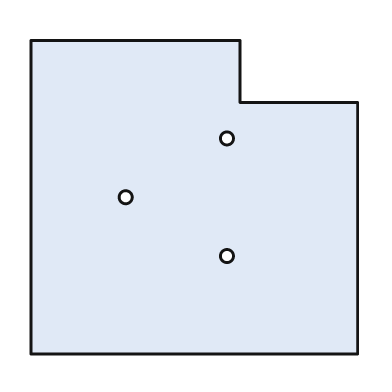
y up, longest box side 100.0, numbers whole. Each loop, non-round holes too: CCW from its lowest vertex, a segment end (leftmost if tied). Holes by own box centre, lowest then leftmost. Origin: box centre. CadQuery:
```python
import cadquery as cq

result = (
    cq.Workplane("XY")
    .moveTo(-50.0, -48.0)
    .lineTo(50.0, -48.0)
    .lineTo(50.0, 29.0)
    .lineTo(14.0, 29.0)
    .lineTo(14.0, 48.0)
    .lineTo(-50.0, 48.0)
    .close()
    .moveTo(10.0, -18.0)
    .circle(2.0)
    .moveTo(-21.0, 0.0)
    .circle(2.0)
    .moveTo(10.0, 18.0)
    .circle(2.0)
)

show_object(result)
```